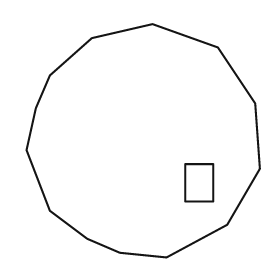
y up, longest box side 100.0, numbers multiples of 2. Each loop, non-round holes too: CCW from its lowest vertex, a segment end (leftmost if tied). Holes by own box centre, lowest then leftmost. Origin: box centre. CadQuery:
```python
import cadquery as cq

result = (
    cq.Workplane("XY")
    .moveTo(10.0, -50.0)
    .lineTo(36.0, -36.0)
    .lineTo(50.0, -12.0)
    .lineTo(48.0, 16.0)
    .lineTo(32.0, 40.0)
    .lineTo(4.0, 50.0)
    .lineTo(-22.0, 44.0)
    .lineTo(-40.0, 28.0)
    .lineTo(-46.0, 14.0)
    .lineTo(-50.0, -4.0)
    .lineTo(-40.0, -30.0)
    .lineTo(-24.0, -42.0)
    .lineTo(-10.0, -48.0)
    .close()
    .moveTo(18.0, -26.0)
    .lineTo(30.0, -26.0)
    .lineTo(30.0, -10.0)
    .lineTo(18.0, -10.0)
    .close()
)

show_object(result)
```